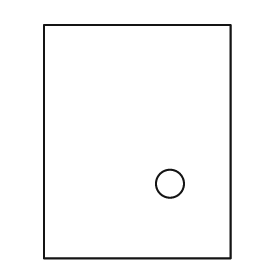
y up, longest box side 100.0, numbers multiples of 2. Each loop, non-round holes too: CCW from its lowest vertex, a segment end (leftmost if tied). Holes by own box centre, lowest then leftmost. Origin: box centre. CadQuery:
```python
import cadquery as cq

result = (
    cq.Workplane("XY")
    .moveTo(-40.0, -50.0)
    .lineTo(40.0, -50.0)
    .lineTo(40.0, 50.0)
    .lineTo(-40.0, 50.0)
    .close()
    .moveTo(14.0, -18.0)
    .circle(6.0)
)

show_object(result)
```